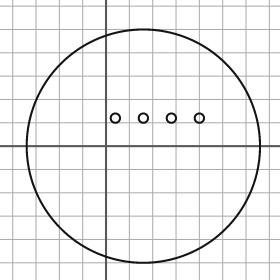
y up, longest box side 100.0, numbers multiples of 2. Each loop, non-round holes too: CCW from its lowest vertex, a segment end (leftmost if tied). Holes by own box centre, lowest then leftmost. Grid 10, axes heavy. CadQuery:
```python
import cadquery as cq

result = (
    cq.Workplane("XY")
    .moveTo(16.0, 0.0)
    .circle(50.0)
    .moveTo(4.0, 12.0)
    .circle(2.0)
    .moveTo(16.0, 12.0)
    .circle(2.0)
    .moveTo(28.0, 12.0)
    .circle(2.0)
    .moveTo(40.0, 12.0)
    .circle(2.0)
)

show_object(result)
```